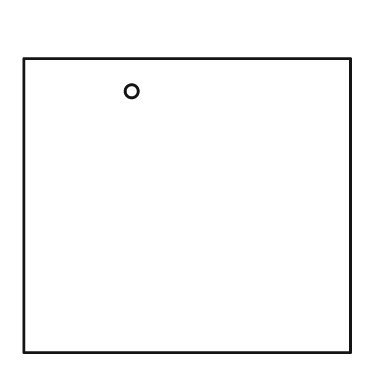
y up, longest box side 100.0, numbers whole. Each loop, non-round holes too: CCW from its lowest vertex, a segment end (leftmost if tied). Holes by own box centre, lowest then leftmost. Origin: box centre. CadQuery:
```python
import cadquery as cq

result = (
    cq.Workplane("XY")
    .moveTo(-50.0, -45.0)
    .lineTo(50.0, -45.0)
    .lineTo(50.0, 45.0)
    .lineTo(-50.0, 45.0)
    .close()
    .moveTo(-17.0, 35.0)
    .circle(2.0)
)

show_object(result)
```